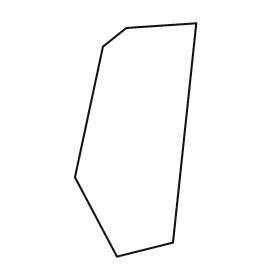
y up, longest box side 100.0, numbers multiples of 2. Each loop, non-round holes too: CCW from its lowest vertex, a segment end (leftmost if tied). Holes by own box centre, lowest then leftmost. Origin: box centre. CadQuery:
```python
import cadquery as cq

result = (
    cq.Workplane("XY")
    .moveTo(-8.0, -50.0)
    .lineTo(16.0, -44.0)
    .lineTo(26.0, 50.0)
    .lineTo(-4.0, 48.0)
    .lineTo(-14.0, 40.0)
    .lineTo(-26.0, -16.0)
    .close()
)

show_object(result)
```